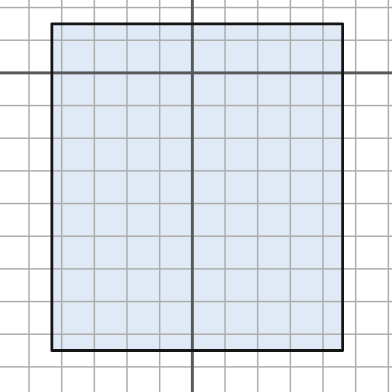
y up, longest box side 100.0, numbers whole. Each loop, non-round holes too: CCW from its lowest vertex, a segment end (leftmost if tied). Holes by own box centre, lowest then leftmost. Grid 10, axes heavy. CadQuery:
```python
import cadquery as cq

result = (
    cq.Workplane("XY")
    .moveTo(-43.0, -85.0)
    .lineTo(46.0, -85.0)
    .lineTo(46.0, 15.0)
    .lineTo(-43.0, 15.0)
    .close()
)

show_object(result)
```